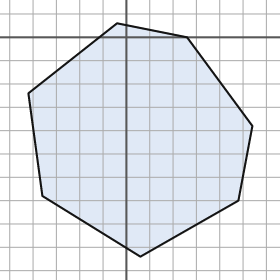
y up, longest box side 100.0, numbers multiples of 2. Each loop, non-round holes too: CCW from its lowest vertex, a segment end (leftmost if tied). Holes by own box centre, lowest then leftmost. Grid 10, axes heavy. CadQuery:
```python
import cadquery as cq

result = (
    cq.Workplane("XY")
    .moveTo(6.0, -94.0)
    .lineTo(48.0, -70.0)
    .lineTo(54.0, -38.0)
    .lineTo(26.0, 0.0)
    .lineTo(-4.0, 6.0)
    .lineTo(-42.0, -24.0)
    .lineTo(-36.0, -68.0)
    .close()
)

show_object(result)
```